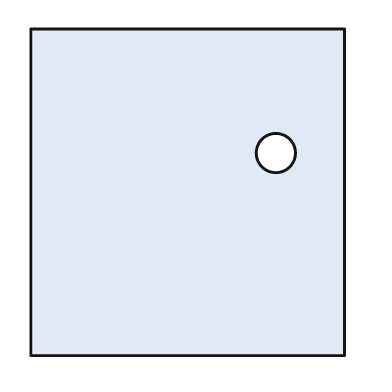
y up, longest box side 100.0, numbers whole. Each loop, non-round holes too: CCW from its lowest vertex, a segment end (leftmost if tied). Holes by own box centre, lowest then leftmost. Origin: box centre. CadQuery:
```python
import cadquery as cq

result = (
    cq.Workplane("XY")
    .moveTo(-48.0, -50.0)
    .lineTo(48.0, -50.0)
    .lineTo(48.0, 50.0)
    .lineTo(-48.0, 50.0)
    .close()
    .moveTo(27.0, 12.0)
    .circle(6.0)
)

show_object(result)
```